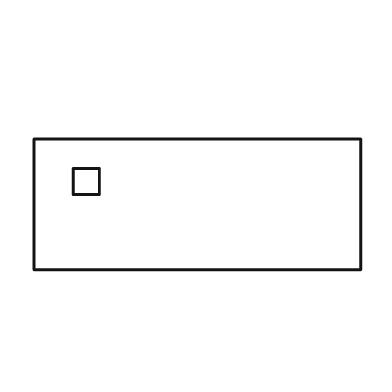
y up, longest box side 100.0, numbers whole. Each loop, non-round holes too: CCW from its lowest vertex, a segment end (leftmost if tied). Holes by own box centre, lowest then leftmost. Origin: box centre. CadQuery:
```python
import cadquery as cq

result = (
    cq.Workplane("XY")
    .moveTo(-50.0, -20.0)
    .lineTo(50.0, -20.0)
    .lineTo(50.0, 20.0)
    .lineTo(-50.0, 20.0)
    .close()
    .moveTo(-38.0, 3.0)
    .lineTo(-30.0, 3.0)
    .lineTo(-30.0, 11.0)
    .lineTo(-38.0, 11.0)
    .close()
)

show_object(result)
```